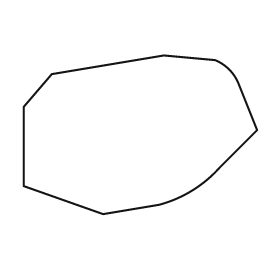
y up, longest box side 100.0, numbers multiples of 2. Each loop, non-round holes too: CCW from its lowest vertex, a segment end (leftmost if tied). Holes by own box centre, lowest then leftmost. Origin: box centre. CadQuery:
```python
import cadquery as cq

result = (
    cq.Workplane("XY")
    .moveTo(-16.0, -34.0)
    .lineTo(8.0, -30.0)
    .threePointArc((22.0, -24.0), (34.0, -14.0))
    .lineTo(50.0, 2.0)
    .lineTo(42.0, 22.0)
    .threePointArc((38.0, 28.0), (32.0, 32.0))
    .lineTo(10.0, 34.0)
    .lineTo(-38.0, 26.0)
    .lineTo(-50.0, 12.0)
    .lineTo(-50.0, -22.0)
    .close()
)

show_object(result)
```